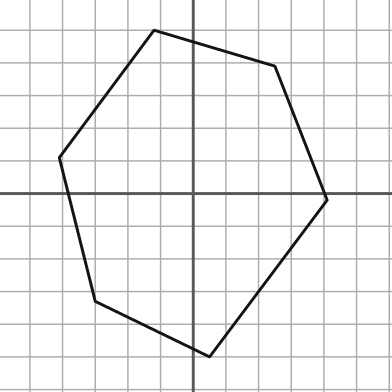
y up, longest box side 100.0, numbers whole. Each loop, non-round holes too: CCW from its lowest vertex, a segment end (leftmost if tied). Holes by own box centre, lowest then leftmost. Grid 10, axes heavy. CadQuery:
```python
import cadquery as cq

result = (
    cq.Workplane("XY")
    .moveTo(5.0, -50.0)
    .lineTo(41.0, -2.0)
    .lineTo(25.0, 39.0)
    .lineTo(-12.0, 50.0)
    .lineTo(-41.0, 11.0)
    .lineTo(-30.0, -33.0)
    .close()
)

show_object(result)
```